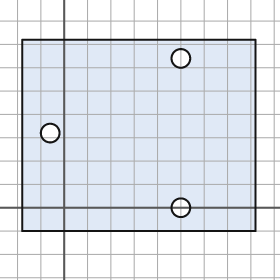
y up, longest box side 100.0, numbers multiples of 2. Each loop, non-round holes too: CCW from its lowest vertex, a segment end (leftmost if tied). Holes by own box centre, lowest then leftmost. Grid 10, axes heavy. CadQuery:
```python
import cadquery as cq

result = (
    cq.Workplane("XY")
    .moveTo(-18.0, -10.0)
    .lineTo(82.0, -10.0)
    .lineTo(82.0, 72.0)
    .lineTo(-18.0, 72.0)
    .close()
    .moveTo(50.0, 0.0)
    .circle(4.0)
    .moveTo(-6.0, 32.0)
    .circle(4.0)
    .moveTo(50.0, 64.0)
    .circle(4.0)
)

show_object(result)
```